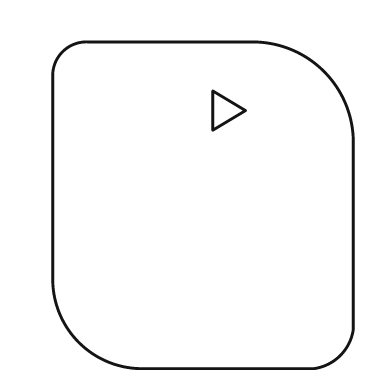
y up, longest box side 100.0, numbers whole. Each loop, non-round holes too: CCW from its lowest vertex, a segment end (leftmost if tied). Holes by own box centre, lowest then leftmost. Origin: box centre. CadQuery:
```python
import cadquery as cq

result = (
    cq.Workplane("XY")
    .moveTo(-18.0, -50.0)
    .lineTo(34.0, -50.0)
    .threePointArc((42.0, -46.0), (46.0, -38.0))
    .lineTo(46.0, 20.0)
    .threePointArc((37.0, 41.0), (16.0, 50.0))
    .lineTo(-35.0, 50.0)
    .threePointArc((-43.0, 47.0), (-46.0, 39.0))
    .lineTo(-46.0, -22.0)
    .threePointArc((-38.0, -42.0), (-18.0, -50.0))
    .close()
    .moveTo(3.0, 23.0)
    .lineTo(13.0, 29.0)
    .lineTo(3.0, 35.0)
    .close()
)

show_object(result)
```